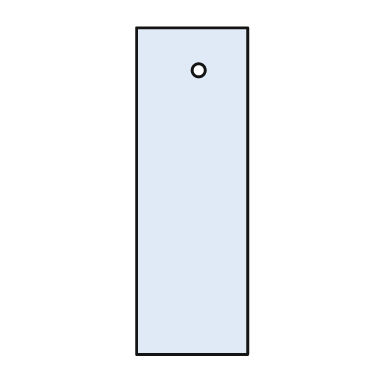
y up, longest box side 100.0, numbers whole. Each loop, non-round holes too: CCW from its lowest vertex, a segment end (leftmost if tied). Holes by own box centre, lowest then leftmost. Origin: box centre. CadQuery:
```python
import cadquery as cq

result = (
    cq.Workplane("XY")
    .moveTo(-17.0, -50.0)
    .lineTo(17.0, -50.0)
    .lineTo(17.0, 50.0)
    .lineTo(-17.0, 50.0)
    .close()
    .moveTo(2.0, 37.0)
    .circle(2.0)
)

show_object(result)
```